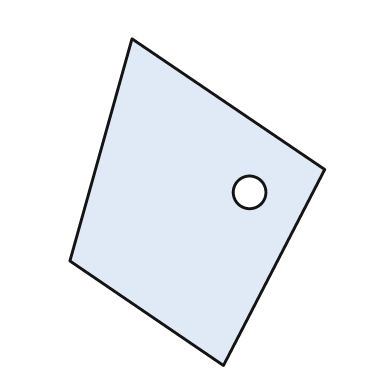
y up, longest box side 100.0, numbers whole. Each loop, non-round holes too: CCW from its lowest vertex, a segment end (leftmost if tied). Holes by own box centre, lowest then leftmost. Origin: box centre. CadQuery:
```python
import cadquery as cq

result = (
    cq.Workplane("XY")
    .moveTo(8.0, -50.0)
    .lineTo(39.0, 10.0)
    .lineTo(-20.0, 50.0)
    .lineTo(-39.0, -18.0)
    .close()
    .moveTo(16.0, 3.0)
    .circle(5.0)
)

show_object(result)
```